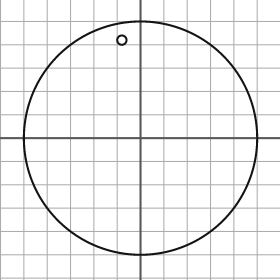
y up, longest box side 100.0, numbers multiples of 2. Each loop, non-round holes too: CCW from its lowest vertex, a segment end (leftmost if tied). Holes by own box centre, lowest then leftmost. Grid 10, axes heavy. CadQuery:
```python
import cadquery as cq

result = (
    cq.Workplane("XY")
    .moveTo(0.0, 0.0)
    .circle(50.0)
    .moveTo(-8.0, 42.0)
    .circle(2.0)
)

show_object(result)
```